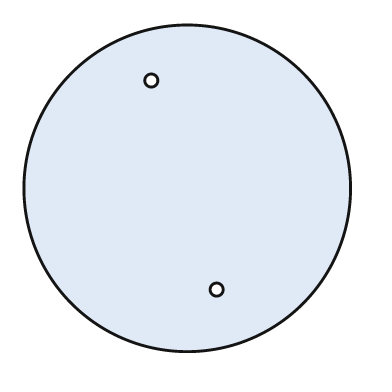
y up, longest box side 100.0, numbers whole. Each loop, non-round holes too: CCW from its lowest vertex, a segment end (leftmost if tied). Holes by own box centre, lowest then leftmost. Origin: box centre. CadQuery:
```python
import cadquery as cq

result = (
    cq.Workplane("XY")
    .moveTo(0.0, 0.0)
    .circle(50.0)
    .moveTo(9.0, -31.0)
    .circle(2.0)
    .moveTo(-11.0, 33.0)
    .circle(2.0)
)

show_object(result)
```